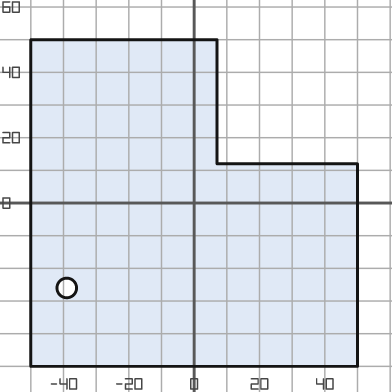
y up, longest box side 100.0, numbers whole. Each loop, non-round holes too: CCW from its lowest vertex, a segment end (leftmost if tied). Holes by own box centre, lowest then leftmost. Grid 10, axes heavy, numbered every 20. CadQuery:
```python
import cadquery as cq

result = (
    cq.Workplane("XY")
    .moveTo(-50.0, -50.0)
    .lineTo(50.0, -50.0)
    .lineTo(50.0, 12.0)
    .lineTo(7.0, 12.0)
    .lineTo(7.0, 50.0)
    .lineTo(-50.0, 50.0)
    .close()
    .moveTo(-39.0, -26.0)
    .circle(3.0)
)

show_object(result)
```